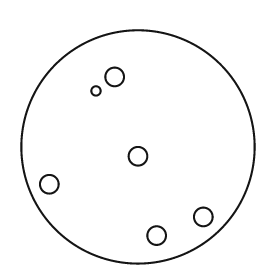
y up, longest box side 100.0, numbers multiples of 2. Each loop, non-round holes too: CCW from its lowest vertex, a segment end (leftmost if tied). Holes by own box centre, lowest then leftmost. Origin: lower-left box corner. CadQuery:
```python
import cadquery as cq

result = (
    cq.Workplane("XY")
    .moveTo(50.0, 50.0)
    .circle(50.0)
    .moveTo(58.0, 12.0)
    .circle(4.0)
    .moveTo(78.0, 20.0)
    .circle(4.0)
    .moveTo(12.0, 34.0)
    .circle(4.0)
    .moveTo(50.0, 46.0)
    .circle(4.0)
    .moveTo(32.0, 74.0)
    .circle(2.0)
    .moveTo(40.0, 80.0)
    .circle(4.0)
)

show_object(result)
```